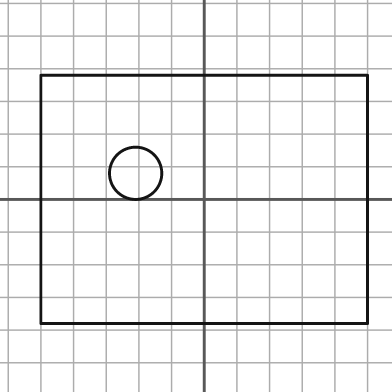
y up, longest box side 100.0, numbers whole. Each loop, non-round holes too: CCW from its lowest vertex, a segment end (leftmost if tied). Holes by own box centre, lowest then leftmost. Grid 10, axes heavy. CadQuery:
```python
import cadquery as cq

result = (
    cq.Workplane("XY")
    .moveTo(-50.0, -38.0)
    .lineTo(50.0, -38.0)
    .lineTo(50.0, 38.0)
    .lineTo(-50.0, 38.0)
    .close()
    .moveTo(-21.0, 8.0)
    .circle(8.0)
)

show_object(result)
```